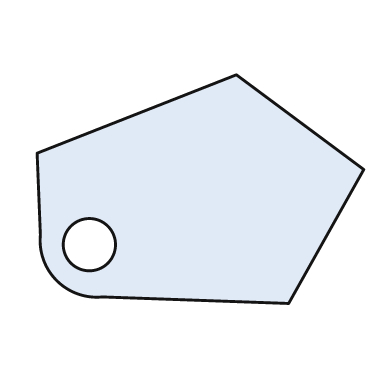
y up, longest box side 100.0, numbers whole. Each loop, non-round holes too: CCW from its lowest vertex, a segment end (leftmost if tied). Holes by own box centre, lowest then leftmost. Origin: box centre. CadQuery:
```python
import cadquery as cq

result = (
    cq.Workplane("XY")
    .moveTo(27.0, -35.0)
    .lineTo(50.0, 6.0)
    .lineTo(11.0, 35.0)
    .lineTo(-50.0, 11.0)
    .lineTo(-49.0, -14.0)
    .threePointArc((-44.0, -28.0), (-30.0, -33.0))
    .close()
    .moveTo(-34.0, -17.0)
    .circle(8.0)
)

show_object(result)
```